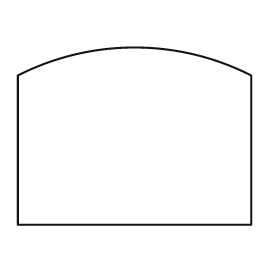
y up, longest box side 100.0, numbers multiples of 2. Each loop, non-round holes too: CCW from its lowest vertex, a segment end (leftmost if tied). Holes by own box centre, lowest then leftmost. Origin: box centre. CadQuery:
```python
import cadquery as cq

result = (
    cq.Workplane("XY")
    .moveTo(-50.0, -38.0)
    .lineTo(50.0, -38.0)
    .lineTo(50.0, 26.0)
    .threePointArc((0.0, 38.0), (-50.0, 26.0))
    .close()
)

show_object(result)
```